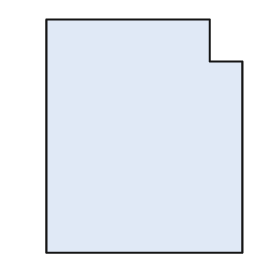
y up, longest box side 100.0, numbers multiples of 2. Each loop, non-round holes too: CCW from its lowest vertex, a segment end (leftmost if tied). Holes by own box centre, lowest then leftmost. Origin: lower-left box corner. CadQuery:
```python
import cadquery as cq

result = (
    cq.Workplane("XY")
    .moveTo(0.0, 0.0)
    .lineTo(84.0, 0.0)
    .lineTo(84.0, 82.0)
    .lineTo(70.0, 82.0)
    .lineTo(70.0, 100.0)
    .lineTo(0.0, 100.0)
    .close()
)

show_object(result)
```